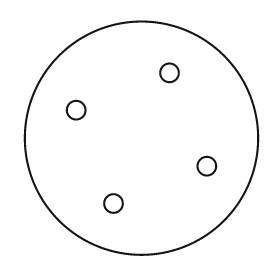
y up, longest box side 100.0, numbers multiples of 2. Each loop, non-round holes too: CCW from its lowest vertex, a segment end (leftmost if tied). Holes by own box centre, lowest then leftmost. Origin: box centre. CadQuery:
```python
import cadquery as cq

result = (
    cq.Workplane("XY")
    .moveTo(0.0, 0.0)
    .circle(50.0)
    .moveTo(-12.0, -28.0)
    .circle(4.0)
    .moveTo(28.0, -12.0)
    .circle(4.0)
    .moveTo(-28.0, 12.0)
    .circle(4.0)
    .moveTo(12.0, 28.0)
    .circle(4.0)
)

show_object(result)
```